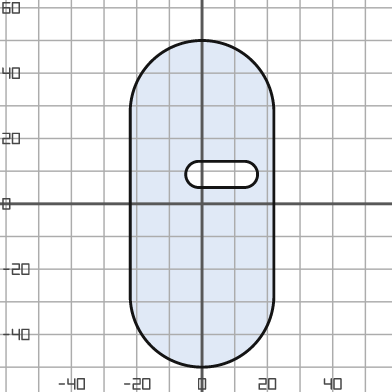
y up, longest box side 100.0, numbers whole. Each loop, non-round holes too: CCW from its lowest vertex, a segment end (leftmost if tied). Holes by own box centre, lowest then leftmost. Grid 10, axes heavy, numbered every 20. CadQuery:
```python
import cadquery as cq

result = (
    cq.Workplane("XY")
    .moveTo(-22.0, -28.0)
    .threePointArc((0.0, -50.0), (22.0, -28.0))
    .lineTo(22.0, 28.0)
    .threePointArc((0.0, 50.0), (-22.0, 28.0))
    .close()
    .moveTo(-1.0, 5.0)
    .lineTo(13.0, 5.0)
    .threePointArc((17.0, 9.0), (13.0, 13.0))
    .lineTo(-1.0, 13.0)
    .threePointArc((-5.0, 9.0), (-1.0, 5.0))
    .close()
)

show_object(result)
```